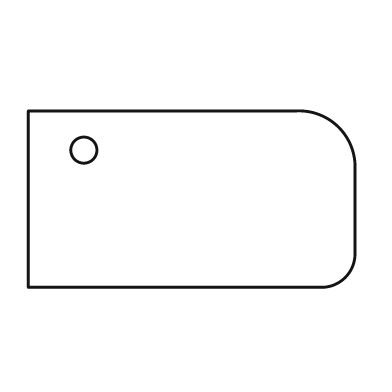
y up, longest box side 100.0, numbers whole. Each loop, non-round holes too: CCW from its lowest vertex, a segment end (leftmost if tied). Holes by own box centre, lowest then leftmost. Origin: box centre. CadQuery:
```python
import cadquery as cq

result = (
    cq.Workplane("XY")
    .moveTo(-50.0, -27.0)
    .lineTo(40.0, -27.0)
    .threePointArc((47.0, -24.0), (50.0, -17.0))
    .lineTo(50.0, 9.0)
    .threePointArc((45.0, 22.0), (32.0, 27.0))
    .lineTo(-50.0, 27.0)
    .close()
    .moveTo(-33.0, 15.0)
    .circle(4.0)
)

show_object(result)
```